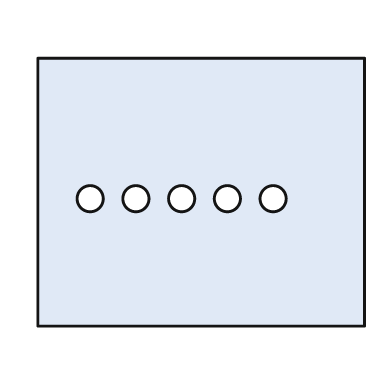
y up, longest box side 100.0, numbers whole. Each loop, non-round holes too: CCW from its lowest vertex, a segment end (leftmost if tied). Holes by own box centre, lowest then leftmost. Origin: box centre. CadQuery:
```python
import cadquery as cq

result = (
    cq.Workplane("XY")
    .moveTo(-50.0, -41.0)
    .lineTo(50.0, -41.0)
    .lineTo(50.0, 41.0)
    .lineTo(-50.0, 41.0)
    .close()
    .moveTo(-34.0, -2.0)
    .circle(4.0)
    .moveTo(-20.0, -2.0)
    .circle(4.0)
    .moveTo(-6.0, -2.0)
    .circle(4.0)
    .moveTo(8.0, -2.0)
    .circle(4.0)
    .moveTo(22.0, -2.0)
    .circle(4.0)
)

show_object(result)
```